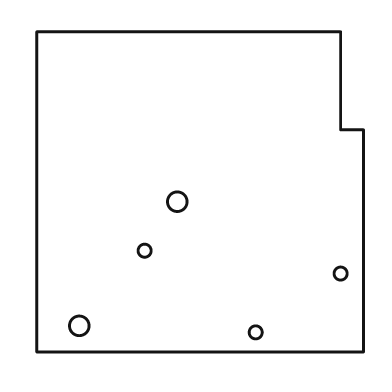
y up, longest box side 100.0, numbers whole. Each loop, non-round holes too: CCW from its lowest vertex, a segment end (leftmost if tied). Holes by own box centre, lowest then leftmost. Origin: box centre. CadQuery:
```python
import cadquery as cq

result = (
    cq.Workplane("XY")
    .moveTo(-50.0, -49.0)
    .lineTo(50.0, -49.0)
    .lineTo(50.0, 19.0)
    .lineTo(43.0, 19.0)
    .lineTo(43.0, 49.0)
    .lineTo(-50.0, 49.0)
    .close()
    .moveTo(17.0, -43.0)
    .circle(2.0)
    .moveTo(-37.0, -41.0)
    .circle(3.0)
    .moveTo(43.0, -25.0)
    .circle(2.0)
    .moveTo(-17.0, -18.0)
    .circle(2.0)
    .moveTo(-7.0, -3.0)
    .circle(3.0)
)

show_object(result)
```